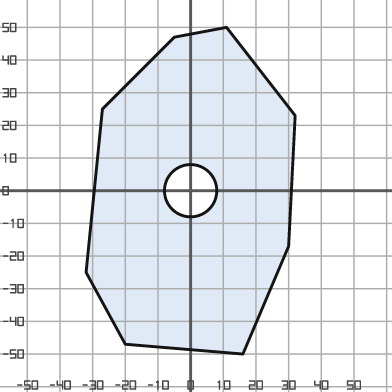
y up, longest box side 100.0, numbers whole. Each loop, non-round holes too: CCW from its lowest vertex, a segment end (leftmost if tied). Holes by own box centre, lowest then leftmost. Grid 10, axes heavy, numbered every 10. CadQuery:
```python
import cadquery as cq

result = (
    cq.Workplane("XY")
    .moveTo(16.0, -50.0)
    .lineTo(30.0, -17.0)
    .lineTo(32.0, 23.0)
    .lineTo(11.0, 50.0)
    .lineTo(-5.0, 47.0)
    .lineTo(-27.0, 25.0)
    .lineTo(-32.0, -25.0)
    .lineTo(-20.0, -47.0)
    .close()
    .moveTo(0.0, 0.0)
    .circle(8.0)
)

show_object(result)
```